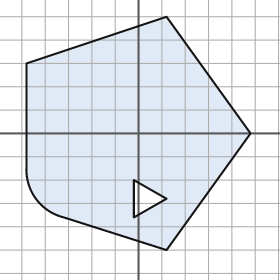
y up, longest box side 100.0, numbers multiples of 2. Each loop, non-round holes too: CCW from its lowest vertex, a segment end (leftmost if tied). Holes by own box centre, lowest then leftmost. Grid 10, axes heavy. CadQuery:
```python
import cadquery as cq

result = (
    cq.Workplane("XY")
    .moveTo(12.0, -50.0)
    .lineTo(48.0, 0.0)
    .lineTo(12.0, 50.0)
    .lineTo(-48.0, 30.0)
    .lineTo(-48.0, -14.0)
    .threePointArc((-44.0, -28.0), (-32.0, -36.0))
    .close()
    .moveTo(-2.0, -36.0)
    .lineTo(12.0, -28.0)
    .lineTo(-2.0, -20.0)
    .close()
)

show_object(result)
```